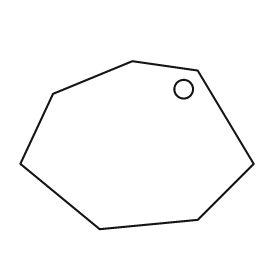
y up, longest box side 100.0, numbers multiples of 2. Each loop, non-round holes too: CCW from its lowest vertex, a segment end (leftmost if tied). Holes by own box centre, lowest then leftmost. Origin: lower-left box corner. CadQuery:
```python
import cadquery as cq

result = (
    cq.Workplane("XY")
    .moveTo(34.0, 0.0)
    .lineTo(76.0, 4.0)
    .lineTo(100.0, 28.0)
    .lineTo(76.0, 68.0)
    .lineTo(48.0, 72.0)
    .lineTo(14.0, 58.0)
    .lineTo(0.0, 28.0)
    .close()
    .moveTo(70.0, 60.0)
    .circle(4.0)
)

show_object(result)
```